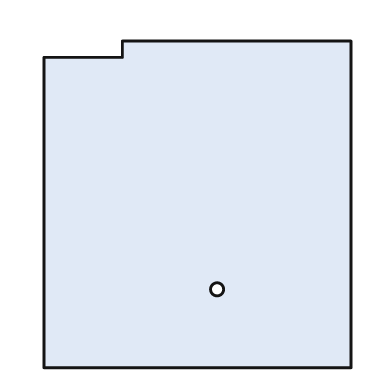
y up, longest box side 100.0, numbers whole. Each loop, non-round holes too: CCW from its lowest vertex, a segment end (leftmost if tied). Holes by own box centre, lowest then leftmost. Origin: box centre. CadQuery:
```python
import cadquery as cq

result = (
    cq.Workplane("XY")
    .moveTo(-47.0, -50.0)
    .lineTo(47.0, -50.0)
    .lineTo(47.0, 50.0)
    .lineTo(-23.0, 50.0)
    .lineTo(-23.0, 45.0)
    .lineTo(-47.0, 45.0)
    .close()
    .moveTo(6.0, -26.0)
    .circle(2.0)
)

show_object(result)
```